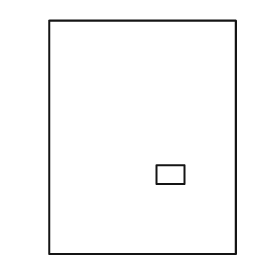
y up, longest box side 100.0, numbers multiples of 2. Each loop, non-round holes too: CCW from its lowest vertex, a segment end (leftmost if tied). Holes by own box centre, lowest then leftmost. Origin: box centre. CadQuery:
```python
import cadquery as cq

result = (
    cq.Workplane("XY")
    .moveTo(-40.0, -50.0)
    .lineTo(40.0, -50.0)
    .lineTo(40.0, 50.0)
    .lineTo(-40.0, 50.0)
    .close()
    .moveTo(6.0, -20.0)
    .lineTo(18.0, -20.0)
    .lineTo(18.0, -12.0)
    .lineTo(6.0, -12.0)
    .close()
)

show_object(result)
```